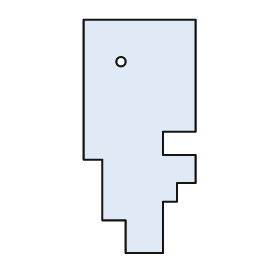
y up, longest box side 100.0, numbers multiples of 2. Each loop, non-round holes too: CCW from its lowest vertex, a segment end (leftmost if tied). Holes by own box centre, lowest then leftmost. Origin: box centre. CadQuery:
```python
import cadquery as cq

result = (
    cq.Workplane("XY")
    .moveTo(-6.0, -50.0)
    .lineTo(10.0, -50.0)
    .lineTo(10.0, -28.0)
    .lineTo(16.0, -28.0)
    .lineTo(16.0, -20.0)
    .lineTo(24.0, -20.0)
    .lineTo(24.0, -8.0)
    .lineTo(10.0, -8.0)
    .lineTo(10.0, 2.0)
    .lineTo(24.0, 2.0)
    .lineTo(24.0, 50.0)
    .lineTo(-24.0, 50.0)
    .lineTo(-24.0, -10.0)
    .lineTo(-16.0, -10.0)
    .lineTo(-16.0, -36.0)
    .lineTo(-6.0, -36.0)
    .close()
    .moveTo(-8.0, 32.0)
    .circle(2.0)
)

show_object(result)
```